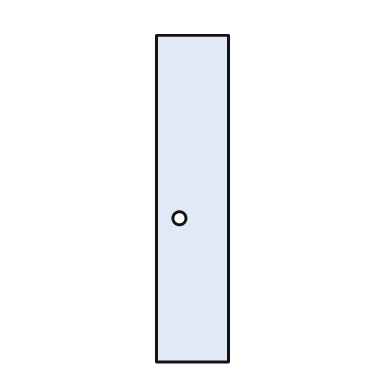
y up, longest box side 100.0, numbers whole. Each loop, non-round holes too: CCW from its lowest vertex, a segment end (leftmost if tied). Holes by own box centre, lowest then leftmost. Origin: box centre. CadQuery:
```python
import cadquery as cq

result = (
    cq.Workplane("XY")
    .moveTo(-11.0, -50.0)
    .lineTo(11.0, -50.0)
    .lineTo(11.0, 50.0)
    .lineTo(-11.0, 50.0)
    .close()
    .moveTo(-4.0, -6.0)
    .circle(2.0)
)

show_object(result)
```